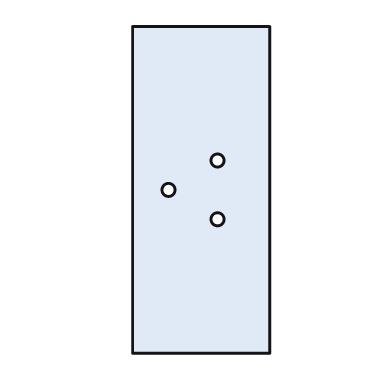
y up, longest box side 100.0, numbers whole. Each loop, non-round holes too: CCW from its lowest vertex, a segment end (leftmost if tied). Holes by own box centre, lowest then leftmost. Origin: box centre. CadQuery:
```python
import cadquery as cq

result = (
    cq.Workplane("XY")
    .moveTo(-21.0, -50.0)
    .lineTo(21.0, -50.0)
    .lineTo(21.0, 50.0)
    .lineTo(-21.0, 50.0)
    .close()
    .moveTo(5.0, -9.0)
    .circle(2.0)
    .moveTo(-10.0, 0.0)
    .circle(2.0)
    .moveTo(5.0, 9.0)
    .circle(2.0)
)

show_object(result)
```